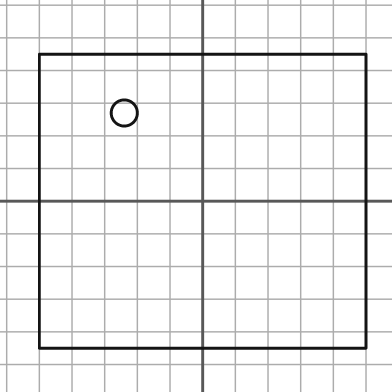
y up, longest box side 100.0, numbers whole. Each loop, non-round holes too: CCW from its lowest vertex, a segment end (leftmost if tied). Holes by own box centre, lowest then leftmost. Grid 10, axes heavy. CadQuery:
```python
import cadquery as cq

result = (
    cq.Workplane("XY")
    .moveTo(-50.0, -45.0)
    .lineTo(50.0, -45.0)
    .lineTo(50.0, 45.0)
    .lineTo(-50.0, 45.0)
    .close()
    .moveTo(-24.0, 27.0)
    .circle(4.0)
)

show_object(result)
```